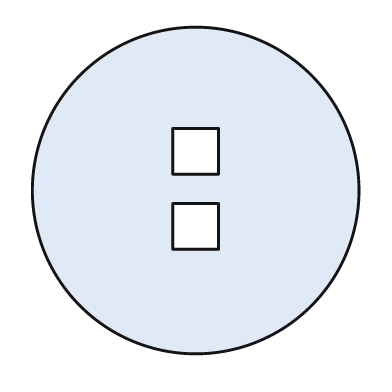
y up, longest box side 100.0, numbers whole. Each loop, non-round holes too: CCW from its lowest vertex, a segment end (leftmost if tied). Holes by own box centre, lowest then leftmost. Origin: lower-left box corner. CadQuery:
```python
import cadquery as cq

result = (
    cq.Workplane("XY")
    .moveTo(50.0, 50.0)
    .circle(50.0)
    .moveTo(43.0, 32.0)
    .lineTo(57.0, 32.0)
    .lineTo(57.0, 46.0)
    .lineTo(43.0, 46.0)
    .close()
    .moveTo(43.0, 55.0)
    .lineTo(57.0, 55.0)
    .lineTo(57.0, 69.0)
    .lineTo(43.0, 69.0)
    .close()
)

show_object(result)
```